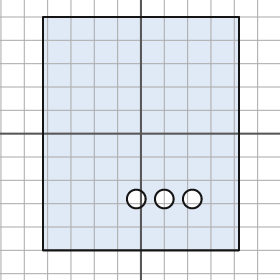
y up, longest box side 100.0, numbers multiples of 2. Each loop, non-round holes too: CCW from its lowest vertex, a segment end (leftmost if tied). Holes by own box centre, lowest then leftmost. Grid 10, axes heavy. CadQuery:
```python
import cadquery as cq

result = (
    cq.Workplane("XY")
    .moveTo(-42.0, -50.0)
    .lineTo(42.0, -50.0)
    .lineTo(42.0, 50.0)
    .lineTo(-42.0, 50.0)
    .close()
    .moveTo(-2.0, -28.0)
    .circle(4.0)
    .moveTo(10.0, -28.0)
    .circle(4.0)
    .moveTo(22.0, -28.0)
    .circle(4.0)
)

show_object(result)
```